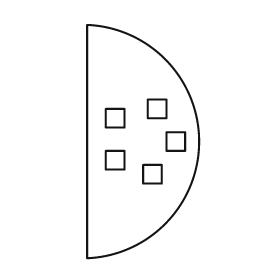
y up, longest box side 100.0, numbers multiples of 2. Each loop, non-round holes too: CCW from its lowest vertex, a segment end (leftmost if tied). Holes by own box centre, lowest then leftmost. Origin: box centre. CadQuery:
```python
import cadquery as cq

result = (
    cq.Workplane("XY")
    .moveTo(-24.0, -50.0)
    .threePointArc((24.0, 0.0), (-24.0, 50.0))
    .close()
    .moveTo(0.0, -18.0)
    .lineTo(8.0, -18.0)
    .lineTo(8.0, -10.0)
    .lineTo(0.0, -10.0)
    .close()
    .moveTo(-16.0, -12.0)
    .lineTo(-8.0, -12.0)
    .lineTo(-8.0, -4.0)
    .lineTo(-16.0, -4.0)
    .close()
    .moveTo(10.0, -4.0)
    .lineTo(18.0, -4.0)
    .lineTo(18.0, 4.0)
    .lineTo(10.0, 4.0)
    .close()
    .moveTo(-16.0, 6.0)
    .lineTo(-8.0, 6.0)
    .lineTo(-8.0, 14.0)
    .lineTo(-16.0, 14.0)
    .close()
    .moveTo(2.0, 10.0)
    .lineTo(10.0, 10.0)
    .lineTo(10.0, 18.0)
    .lineTo(2.0, 18.0)
    .close()
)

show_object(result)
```